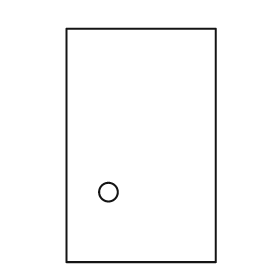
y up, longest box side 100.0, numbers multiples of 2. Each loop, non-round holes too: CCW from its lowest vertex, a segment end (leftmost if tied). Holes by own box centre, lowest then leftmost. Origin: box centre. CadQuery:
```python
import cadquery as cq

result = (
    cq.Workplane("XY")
    .moveTo(-32.0, -50.0)
    .lineTo(32.0, -50.0)
    .lineTo(32.0, 50.0)
    .lineTo(-32.0, 50.0)
    .close()
    .moveTo(-14.0, -20.0)
    .circle(4.0)
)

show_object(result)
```